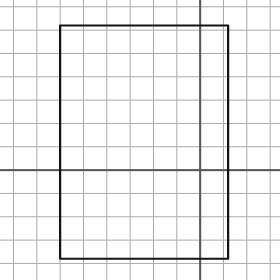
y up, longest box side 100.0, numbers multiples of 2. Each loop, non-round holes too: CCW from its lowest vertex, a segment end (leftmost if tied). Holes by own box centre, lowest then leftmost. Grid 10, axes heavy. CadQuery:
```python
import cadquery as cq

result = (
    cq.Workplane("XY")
    .moveTo(-60.0, -38.0)
    .lineTo(12.0, -38.0)
    .lineTo(12.0, 62.0)
    .lineTo(-60.0, 62.0)
    .close()
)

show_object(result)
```